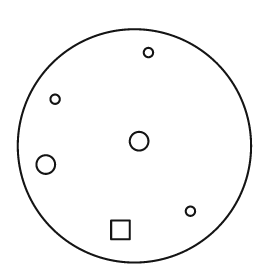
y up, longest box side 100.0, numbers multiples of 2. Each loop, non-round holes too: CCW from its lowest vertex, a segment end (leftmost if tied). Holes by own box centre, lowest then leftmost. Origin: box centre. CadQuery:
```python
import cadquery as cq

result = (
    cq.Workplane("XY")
    .moveTo(0.0, 0.0)
    .circle(50.0)
    .moveTo(-10.0, -40.0)
    .lineTo(-2.0, -40.0)
    .lineTo(-2.0, -32.0)
    .lineTo(-10.0, -32.0)
    .close()
    .moveTo(24.0, -28.0)
    .circle(2.0)
    .moveTo(-38.0, -8.0)
    .circle(4.0)
    .moveTo(2.0, 2.0)
    .circle(4.0)
    .moveTo(-34.0, 20.0)
    .circle(2.0)
    .moveTo(6.0, 40.0)
    .circle(2.0)
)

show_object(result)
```